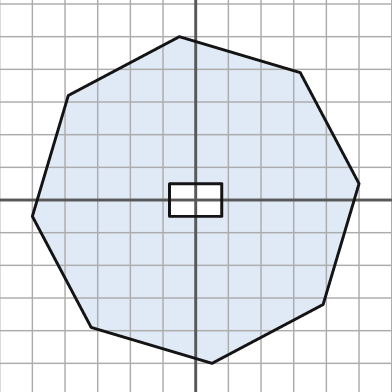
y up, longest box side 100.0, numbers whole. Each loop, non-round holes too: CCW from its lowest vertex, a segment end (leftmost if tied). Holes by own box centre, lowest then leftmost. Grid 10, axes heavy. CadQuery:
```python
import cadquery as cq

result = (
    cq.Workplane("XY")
    .moveTo(5.0, -50.0)
    .lineTo(39.0, -32.0)
    .lineTo(50.0, 5.0)
    .lineTo(32.0, 39.0)
    .lineTo(-5.0, 50.0)
    .lineTo(-39.0, 32.0)
    .lineTo(-50.0, -5.0)
    .lineTo(-32.0, -39.0)
    .close()
    .moveTo(-8.0, -5.0)
    .lineTo(8.0, -5.0)
    .lineTo(8.0, 5.0)
    .lineTo(-8.0, 5.0)
    .close()
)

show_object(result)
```